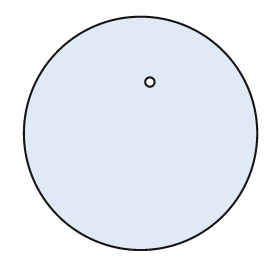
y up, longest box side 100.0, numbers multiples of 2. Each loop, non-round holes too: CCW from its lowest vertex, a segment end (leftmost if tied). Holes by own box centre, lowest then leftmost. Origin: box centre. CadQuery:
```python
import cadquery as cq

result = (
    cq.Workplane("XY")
    .moveTo(0.0, 0.0)
    .circle(50.0)
    .moveTo(4.0, 22.0)
    .circle(2.0)
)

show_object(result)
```